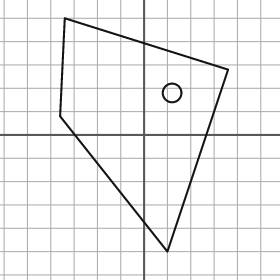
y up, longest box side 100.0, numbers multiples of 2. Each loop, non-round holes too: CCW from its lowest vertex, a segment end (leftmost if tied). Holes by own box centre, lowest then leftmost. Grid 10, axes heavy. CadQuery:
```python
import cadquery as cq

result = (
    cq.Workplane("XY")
    .moveTo(10.0, -50.0)
    .lineTo(36.0, 28.0)
    .lineTo(-34.0, 50.0)
    .lineTo(-36.0, 8.0)
    .close()
    .moveTo(12.0, 18.0)
    .circle(4.0)
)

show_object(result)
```